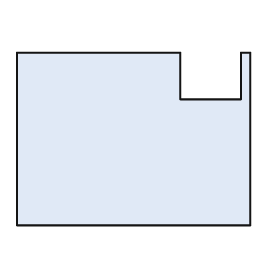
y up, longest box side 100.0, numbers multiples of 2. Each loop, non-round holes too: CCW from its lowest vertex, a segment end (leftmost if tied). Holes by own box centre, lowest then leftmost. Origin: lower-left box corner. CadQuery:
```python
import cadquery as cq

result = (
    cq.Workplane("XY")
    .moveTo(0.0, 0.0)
    .lineTo(100.0, 0.0)
    .lineTo(100.0, 74.0)
    .lineTo(96.0, 74.0)
    .lineTo(96.0, 54.0)
    .lineTo(70.0, 54.0)
    .lineTo(70.0, 74.0)
    .lineTo(0.0, 74.0)
    .close()
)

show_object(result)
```